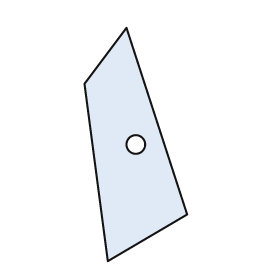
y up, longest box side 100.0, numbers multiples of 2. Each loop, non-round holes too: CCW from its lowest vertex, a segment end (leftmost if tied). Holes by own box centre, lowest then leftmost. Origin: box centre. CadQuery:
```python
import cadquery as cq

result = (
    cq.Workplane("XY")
    .moveTo(-12.0, -50.0)
    .lineTo(22.0, -30.0)
    .lineTo(-4.0, 50.0)
    .lineTo(-22.0, 26.0)
    .close()
    .moveTo(0.0, 0.0)
    .circle(4.0)
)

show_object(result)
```